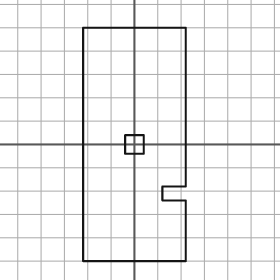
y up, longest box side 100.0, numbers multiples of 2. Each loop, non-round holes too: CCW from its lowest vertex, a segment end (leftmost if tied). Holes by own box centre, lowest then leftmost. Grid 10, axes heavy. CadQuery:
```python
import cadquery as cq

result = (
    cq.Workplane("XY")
    .moveTo(-22.0, -50.0)
    .lineTo(22.0, -50.0)
    .lineTo(22.0, -24.0)
    .lineTo(12.0, -24.0)
    .lineTo(12.0, -18.0)
    .lineTo(22.0, -18.0)
    .lineTo(22.0, 50.0)
    .lineTo(-22.0, 50.0)
    .close()
    .moveTo(-4.0, -4.0)
    .lineTo(4.0, -4.0)
    .lineTo(4.0, 4.0)
    .lineTo(-4.0, 4.0)
    .close()
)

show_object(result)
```